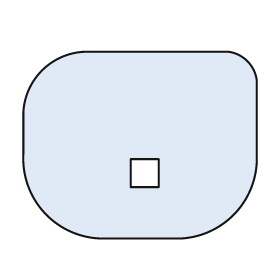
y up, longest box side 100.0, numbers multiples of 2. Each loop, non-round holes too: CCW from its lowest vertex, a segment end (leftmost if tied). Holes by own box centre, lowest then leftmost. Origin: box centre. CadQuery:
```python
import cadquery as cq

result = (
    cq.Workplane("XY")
    .moveTo(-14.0, -40.0)
    .lineTo(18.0, -40.0)
    .threePointArc((40.0, -30.0), (50.0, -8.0))
    .lineTo(50.0, 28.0)
    .threePointArc((46.0, 36.0), (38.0, 40.0))
    .lineTo(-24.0, 40.0)
    .threePointArc((-42.0, 32.0), (-50.0, 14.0))
    .lineTo(-50.0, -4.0)
    .threePointArc((-40.0, -30.0), (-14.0, -40.0))
    .close()
    .moveTo(-4.0, -18.0)
    .lineTo(8.0, -18.0)
    .lineTo(8.0, -6.0)
    .lineTo(-4.0, -6.0)
    .close()
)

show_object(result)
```